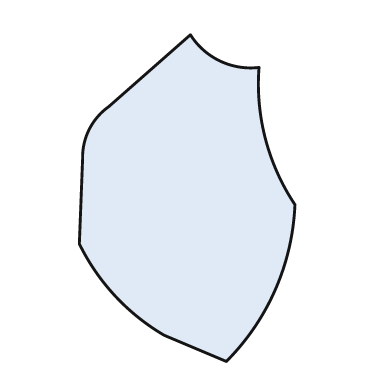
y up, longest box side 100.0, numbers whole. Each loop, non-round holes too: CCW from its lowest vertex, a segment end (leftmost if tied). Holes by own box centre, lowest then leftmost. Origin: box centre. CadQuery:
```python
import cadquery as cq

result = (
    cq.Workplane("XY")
    .moveTo(12.0, -50.0)
    .threePointArc((27.0, -28.0), (33.0, -2.0))
    .threePointArc((24.0, 18.0), (22.0, 40.0))
    .threePointArc((10.0, 42.0), (1.0, 50.0))
    .lineTo(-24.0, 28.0)
    .threePointArc((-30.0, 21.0), (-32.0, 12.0))
    .lineTo(-33.0, -14.0)
    .threePointArc((-22.0, -30.0), (-7.0, -42.0))
    .close()
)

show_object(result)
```